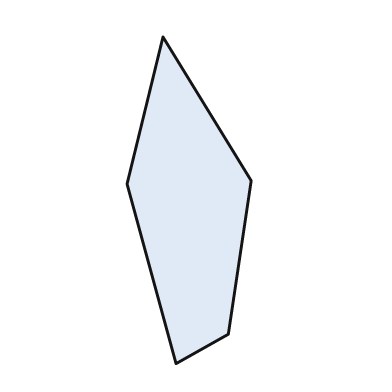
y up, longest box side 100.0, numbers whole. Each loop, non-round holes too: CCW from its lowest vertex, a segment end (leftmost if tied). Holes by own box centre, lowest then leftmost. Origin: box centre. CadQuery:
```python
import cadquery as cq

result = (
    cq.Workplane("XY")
    .moveTo(-4.0, -50.0)
    .lineTo(12.0, -41.0)
    .lineTo(19.0, 6.0)
    .lineTo(-8.0, 50.0)
    .lineTo(-19.0, 5.0)
    .close()
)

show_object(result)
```